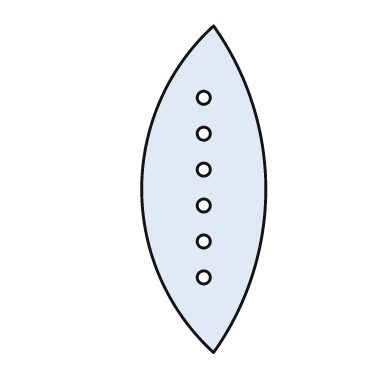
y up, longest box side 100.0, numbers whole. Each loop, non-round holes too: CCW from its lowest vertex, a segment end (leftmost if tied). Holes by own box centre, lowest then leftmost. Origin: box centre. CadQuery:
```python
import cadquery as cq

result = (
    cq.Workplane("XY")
    .moveTo(3.0, -50.0)
    .threePointArc((19.0, 0.0), (3.0, 50.0))
    .threePointArc((-19.0, 0.0), (3.0, -50.0))
    .close()
    .moveTo(0.0, -27.0)
    .circle(2.0)
    .moveTo(0.0, -16.0)
    .circle(2.0)
    .moveTo(0.0, -5.0)
    .circle(2.0)
    .moveTo(0.0, 6.0)
    .circle(2.0)
    .moveTo(0.0, 17.0)
    .circle(2.0)
    .moveTo(0.0, 28.0)
    .circle(2.0)
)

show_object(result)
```